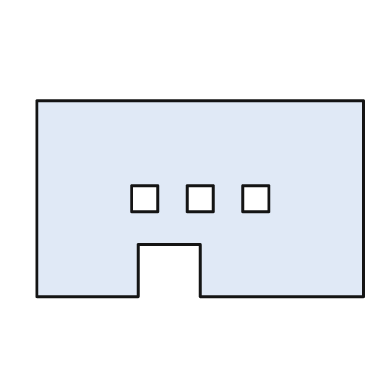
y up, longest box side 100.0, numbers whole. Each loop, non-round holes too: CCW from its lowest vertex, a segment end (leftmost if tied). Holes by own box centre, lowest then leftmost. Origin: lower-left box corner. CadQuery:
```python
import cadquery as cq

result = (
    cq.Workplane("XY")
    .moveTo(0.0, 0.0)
    .lineTo(31.0, 0.0)
    .lineTo(31.0, 16.0)
    .lineTo(50.0, 16.0)
    .lineTo(50.0, 0.0)
    .lineTo(100.0, 0.0)
    .lineTo(100.0, 60.0)
    .lineTo(0.0, 60.0)
    .close()
    .moveTo(29.0, 26.0)
    .lineTo(37.0, 26.0)
    .lineTo(37.0, 34.0)
    .lineTo(29.0, 34.0)
    .close()
    .moveTo(46.0, 26.0)
    .lineTo(54.0, 26.0)
    .lineTo(54.0, 34.0)
    .lineTo(46.0, 34.0)
    .close()
    .moveTo(63.0, 26.0)
    .lineTo(71.0, 26.0)
    .lineTo(71.0, 34.0)
    .lineTo(63.0, 34.0)
    .close()
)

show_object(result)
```